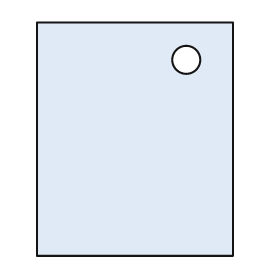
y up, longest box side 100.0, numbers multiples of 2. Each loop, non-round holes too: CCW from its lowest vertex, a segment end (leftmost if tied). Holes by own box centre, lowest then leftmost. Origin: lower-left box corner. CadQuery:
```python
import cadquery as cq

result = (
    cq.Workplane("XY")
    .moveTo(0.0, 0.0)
    .lineTo(84.0, 0.0)
    .lineTo(84.0, 100.0)
    .lineTo(0.0, 100.0)
    .close()
    .moveTo(64.0, 84.0)
    .circle(6.0)
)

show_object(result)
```